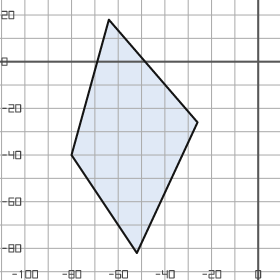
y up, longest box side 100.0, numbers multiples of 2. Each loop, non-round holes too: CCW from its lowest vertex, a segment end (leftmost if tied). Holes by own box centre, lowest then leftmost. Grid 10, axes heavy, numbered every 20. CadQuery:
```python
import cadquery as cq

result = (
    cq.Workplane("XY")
    .moveTo(-52.0, -82.0)
    .lineTo(-26.0, -26.0)
    .lineTo(-64.0, 18.0)
    .lineTo(-80.0, -40.0)
    .close()
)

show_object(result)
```